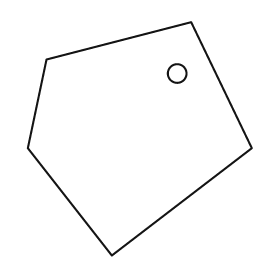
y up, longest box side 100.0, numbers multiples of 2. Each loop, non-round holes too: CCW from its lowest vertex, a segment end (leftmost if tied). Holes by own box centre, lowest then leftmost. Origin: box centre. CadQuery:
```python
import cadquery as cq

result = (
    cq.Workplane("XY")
    .moveTo(-12.0, -50.0)
    .lineTo(48.0, -4.0)
    .lineTo(22.0, 50.0)
    .lineTo(-40.0, 34.0)
    .lineTo(-48.0, -4.0)
    .close()
    .moveTo(16.0, 28.0)
    .circle(4.0)
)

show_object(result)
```